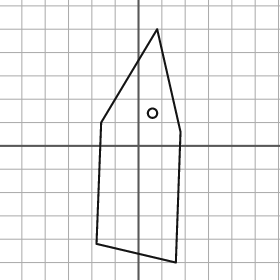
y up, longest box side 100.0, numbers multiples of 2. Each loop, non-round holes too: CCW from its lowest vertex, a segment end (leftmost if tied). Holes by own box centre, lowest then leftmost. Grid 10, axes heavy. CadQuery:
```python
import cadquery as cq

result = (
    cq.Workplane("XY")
    .moveTo(16.0, -50.0)
    .lineTo(18.0, 6.0)
    .lineTo(8.0, 50.0)
    .lineTo(-16.0, 10.0)
    .lineTo(-18.0, -42.0)
    .close()
    .moveTo(6.0, 14.0)
    .circle(2.0)
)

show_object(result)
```